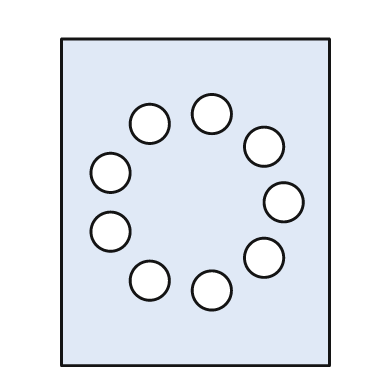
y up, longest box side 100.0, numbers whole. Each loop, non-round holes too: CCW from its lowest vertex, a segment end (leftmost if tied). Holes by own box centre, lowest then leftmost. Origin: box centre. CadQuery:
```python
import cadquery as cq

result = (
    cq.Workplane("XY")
    .moveTo(-41.0, -50.0)
    .lineTo(41.0, -50.0)
    .lineTo(41.0, 50.0)
    .lineTo(-41.0, 50.0)
    .close()
    .moveTo(5.0, -27.0)
    .circle(6.0)
    .moveTo(-14.0, -24.0)
    .circle(6.0)
    .moveTo(21.0, -17.0)
    .circle(6.0)
    .moveTo(-26.0, -9.0)
    .circle(6.0)
    .moveTo(27.0, 0.0)
    .circle(6.0)
    .moveTo(-26.0, 9.0)
    .circle(6.0)
    .moveTo(21.0, 17.0)
    .circle(6.0)
    .moveTo(-14.0, 24.0)
    .circle(6.0)
    .moveTo(5.0, 27.0)
    .circle(6.0)
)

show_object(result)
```